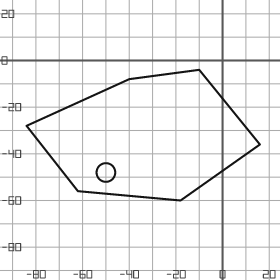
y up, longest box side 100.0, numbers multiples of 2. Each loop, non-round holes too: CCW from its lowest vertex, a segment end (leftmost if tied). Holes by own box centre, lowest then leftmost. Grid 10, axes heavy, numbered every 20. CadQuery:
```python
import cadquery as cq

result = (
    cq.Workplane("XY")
    .moveTo(-18.0, -60.0)
    .lineTo(16.0, -36.0)
    .lineTo(-10.0, -4.0)
    .lineTo(-40.0, -8.0)
    .lineTo(-84.0, -28.0)
    .lineTo(-62.0, -56.0)
    .close()
    .moveTo(-50.0, -48.0)
    .circle(4.0)
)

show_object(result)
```